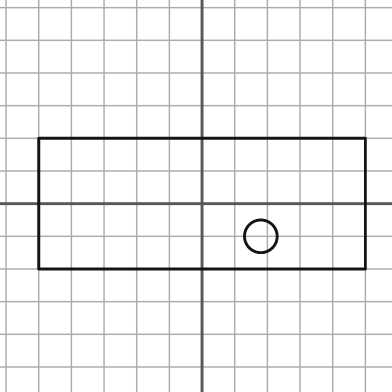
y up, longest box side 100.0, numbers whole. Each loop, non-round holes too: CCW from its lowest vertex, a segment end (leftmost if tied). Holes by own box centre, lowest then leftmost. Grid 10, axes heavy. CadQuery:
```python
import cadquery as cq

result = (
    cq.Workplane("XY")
    .moveTo(-50.0, -20.0)
    .lineTo(50.0, -20.0)
    .lineTo(50.0, 20.0)
    .lineTo(-50.0, 20.0)
    .close()
    .moveTo(18.0, -10.0)
    .circle(5.0)
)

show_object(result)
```